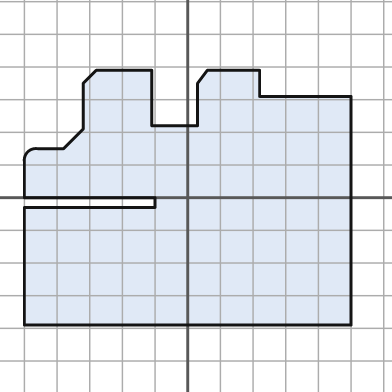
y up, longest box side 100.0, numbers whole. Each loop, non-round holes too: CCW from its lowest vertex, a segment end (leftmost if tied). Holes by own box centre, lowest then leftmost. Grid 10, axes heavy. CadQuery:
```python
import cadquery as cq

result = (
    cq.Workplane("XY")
    .moveTo(-50.0, -39.0)
    .lineTo(50.0, -39.0)
    .lineTo(50.0, 31.0)
    .lineTo(22.0, 31.0)
    .lineTo(22.0, 39.0)
    .lineTo(6.0, 39.0)
    .lineTo(3.0, 35.0)
    .lineTo(3.0, 22.0)
    .lineTo(-11.0, 22.0)
    .lineTo(-11.0, 39.0)
    .lineTo(-28.0, 39.0)
    .lineTo(-32.0, 35.0)
    .lineTo(-32.0, 21.0)
    .lineTo(-38.0, 15.0)
    .lineTo(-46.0, 15.0)
    .threePointArc((-49.0, 14.0), (-50.0, 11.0))
    .lineTo(-50.0, 0.0)
    .lineTo(-10.0, 0.0)
    .lineTo(-10.0, -3.0)
    .lineTo(-50.0, -3.0)
    .close()
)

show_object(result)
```